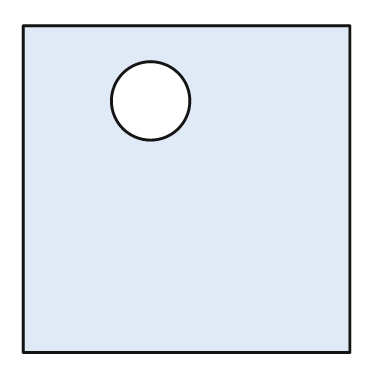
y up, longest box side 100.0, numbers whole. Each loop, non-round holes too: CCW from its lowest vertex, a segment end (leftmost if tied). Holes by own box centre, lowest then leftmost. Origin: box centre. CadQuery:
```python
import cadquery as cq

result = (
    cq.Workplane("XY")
    .moveTo(-50.0, -50.0)
    .lineTo(50.0, -50.0)
    .lineTo(50.0, 50.0)
    .lineTo(-50.0, 50.0)
    .close()
    .moveTo(-11.0, 27.0)
    .circle(12.0)
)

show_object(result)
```